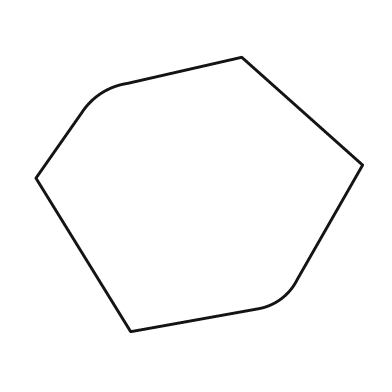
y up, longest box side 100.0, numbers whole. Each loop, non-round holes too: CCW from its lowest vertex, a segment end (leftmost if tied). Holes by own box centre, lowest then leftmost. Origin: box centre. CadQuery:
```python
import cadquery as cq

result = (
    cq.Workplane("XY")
    .moveTo(-21.0, -42.0)
    .lineTo(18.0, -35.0)
    .threePointArc((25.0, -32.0), (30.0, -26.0))
    .lineTo(50.0, 9.0)
    .lineTo(13.0, 42.0)
    .lineTo(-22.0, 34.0)
    .threePointArc((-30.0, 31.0), (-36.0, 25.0))
    .lineTo(-50.0, 5.0)
    .close()
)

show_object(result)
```